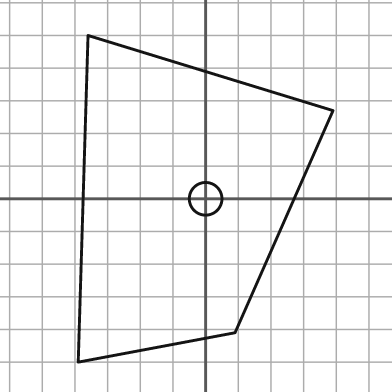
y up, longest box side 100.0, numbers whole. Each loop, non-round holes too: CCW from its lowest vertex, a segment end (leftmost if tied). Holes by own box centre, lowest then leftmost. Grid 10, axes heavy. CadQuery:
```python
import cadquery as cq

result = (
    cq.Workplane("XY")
    .moveTo(-39.0, -50.0)
    .lineTo(9.0, -41.0)
    .lineTo(39.0, 27.0)
    .lineTo(-36.0, 50.0)
    .close()
    .moveTo(0.0, 0.0)
    .circle(5.0)
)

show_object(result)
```